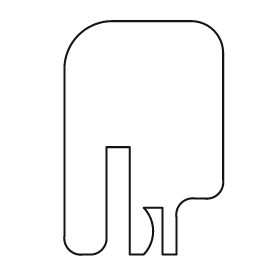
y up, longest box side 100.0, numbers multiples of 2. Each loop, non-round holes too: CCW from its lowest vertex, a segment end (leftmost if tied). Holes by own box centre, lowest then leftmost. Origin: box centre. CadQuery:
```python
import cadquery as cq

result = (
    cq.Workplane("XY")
    .moveTo(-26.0, -50.0)
    .lineTo(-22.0, -50.0)
    .threePointArc((-18.0, -48.0), (-16.0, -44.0))
    .lineTo(-16.0, -4.0)
    .lineTo(-6.0, -4.0)
    .lineTo(-6.0, -50.0)
    .lineTo(0.0, -50.0)
    .threePointArc((4.0, -40.0), (0.0, -30.0))
    .lineTo(8.0, -30.0)
    .lineTo(8.0, -50.0)
    .lineTo(14.0, -50.0)
    .lineTo(14.0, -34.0)
    .threePointArc((16.0, -28.0), (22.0, -26.0))
    .lineTo(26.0, -26.0)
    .threePointArc((32.0, -24.0), (34.0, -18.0))
    .lineTo(34.0, 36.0)
    .threePointArc((30.0, 46.0), (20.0, 50.0))
    .lineTo(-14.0, 50.0)
    .threePointArc((-28.0, 44.0), (-34.0, 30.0))
    .lineTo(-34.0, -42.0)
    .threePointArc((-32.0, -48.0), (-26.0, -50.0))
    .close()
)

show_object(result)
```